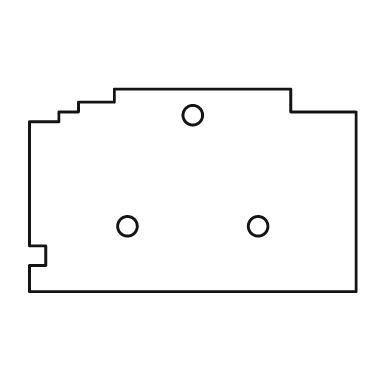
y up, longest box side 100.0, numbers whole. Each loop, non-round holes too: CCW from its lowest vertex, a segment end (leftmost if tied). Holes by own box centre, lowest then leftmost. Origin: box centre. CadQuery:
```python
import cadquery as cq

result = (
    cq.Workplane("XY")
    .moveTo(-50.0, -31.0)
    .lineTo(50.0, -31.0)
    .lineTo(50.0, 24.0)
    .lineTo(30.0, 24.0)
    .lineTo(30.0, 31.0)
    .lineTo(-24.0, 31.0)
    .lineTo(-24.0, 27.0)
    .lineTo(-35.0, 27.0)
    .lineTo(-35.0, 24.0)
    .lineTo(-41.0, 24.0)
    .lineTo(-41.0, 21.0)
    .lineTo(-50.0, 21.0)
    .lineTo(-50.0, -17.0)
    .lineTo(-45.0, -17.0)
    .lineTo(-45.0, -23.0)
    .lineTo(-50.0, -23.0)
    .close()
    .moveTo(-20.0, -11.0)
    .circle(3.0)
    .moveTo(20.0, -11.0)
    .circle(3.0)
    .moveTo(0.0, 23.0)
    .circle(3.0)
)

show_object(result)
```